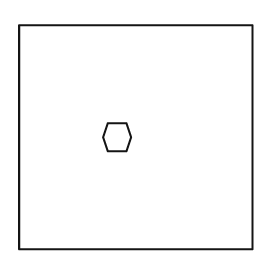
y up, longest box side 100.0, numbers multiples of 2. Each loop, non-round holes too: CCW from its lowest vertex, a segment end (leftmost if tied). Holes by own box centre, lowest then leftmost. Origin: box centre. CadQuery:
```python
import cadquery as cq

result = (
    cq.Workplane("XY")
    .moveTo(-50.0, -48.0)
    .lineTo(50.0, -48.0)
    .lineTo(50.0, 48.0)
    .lineTo(-50.0, 48.0)
    .close()
    .moveTo(-12.0, -6.0)
    .lineTo(-4.0, -6.0)
    .lineTo(-2.0, 0.0)
    .lineTo(-4.0, 6.0)
    .lineTo(-12.0, 6.0)
    .lineTo(-14.0, 0.0)
    .close()
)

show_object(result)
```